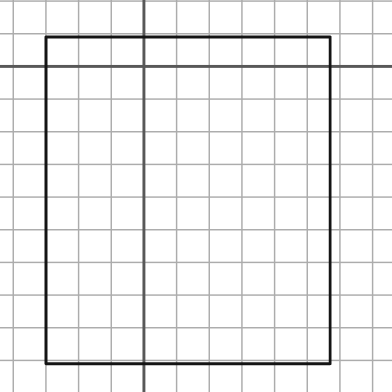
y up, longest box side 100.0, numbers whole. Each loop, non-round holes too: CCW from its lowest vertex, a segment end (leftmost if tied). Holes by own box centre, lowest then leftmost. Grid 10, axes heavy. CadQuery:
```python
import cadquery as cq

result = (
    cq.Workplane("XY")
    .moveTo(-30.0, -91.0)
    .lineTo(57.0, -91.0)
    .lineTo(57.0, 9.0)
    .lineTo(-30.0, 9.0)
    .close()
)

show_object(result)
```